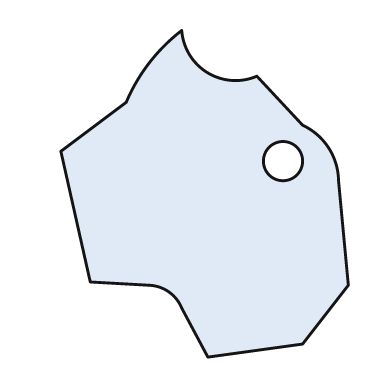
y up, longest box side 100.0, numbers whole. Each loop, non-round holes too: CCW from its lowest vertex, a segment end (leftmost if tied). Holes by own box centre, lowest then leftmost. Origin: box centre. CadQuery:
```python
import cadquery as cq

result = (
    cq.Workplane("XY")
    .moveTo(1.0, -50.0)
    .lineTo(30.0, -46.0)
    .lineTo(44.0, -28.0)
    .lineTo(41.0, 4.0)
    .threePointArc((38.0, 14.0), (30.0, 21.0))
    .lineTo(16.0, 36.0)
    .threePointArc((1.0, 37.0), (-7.0, 50.0))
    .threePointArc((-17.0, 40.0), (-24.0, 28.0))
    .lineTo(-44.0, 13.0)
    .lineTo(-35.0, -27.0)
    .lineTo(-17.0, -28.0)
    .threePointArc((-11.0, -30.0), (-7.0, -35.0))
    .close()
    .moveTo(24.0, 10.0)
    .circle(6.0)
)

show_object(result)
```